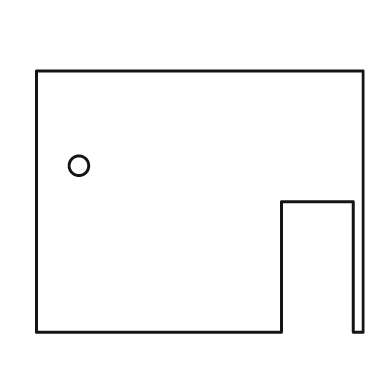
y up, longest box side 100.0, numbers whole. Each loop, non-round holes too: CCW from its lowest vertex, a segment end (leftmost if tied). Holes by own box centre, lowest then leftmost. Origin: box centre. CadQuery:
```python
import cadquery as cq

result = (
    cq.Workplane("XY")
    .moveTo(-50.0, -40.0)
    .lineTo(25.0, -40.0)
    .lineTo(25.0, 0.0)
    .lineTo(47.0, 0.0)
    .lineTo(47.0, -40.0)
    .lineTo(50.0, -40.0)
    .lineTo(50.0, 40.0)
    .lineTo(-50.0, 40.0)
    .close()
    .moveTo(-37.0, 11.0)
    .circle(3.0)
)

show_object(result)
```